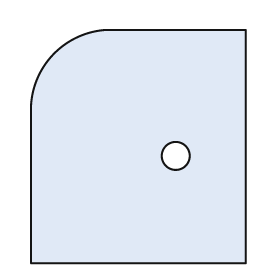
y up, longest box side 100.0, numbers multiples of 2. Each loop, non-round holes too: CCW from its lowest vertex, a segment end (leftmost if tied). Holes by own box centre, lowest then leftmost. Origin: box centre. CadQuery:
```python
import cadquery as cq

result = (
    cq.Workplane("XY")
    .moveTo(-46.0, -50.0)
    .lineTo(46.0, -50.0)
    .lineTo(46.0, 50.0)
    .lineTo(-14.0, 50.0)
    .threePointArc((-36.0, 40.0), (-46.0, 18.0))
    .close()
    .moveTo(16.0, -4.0)
    .circle(6.0)
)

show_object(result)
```